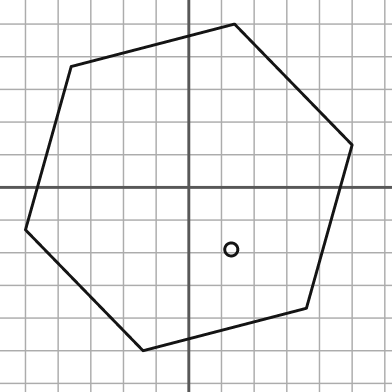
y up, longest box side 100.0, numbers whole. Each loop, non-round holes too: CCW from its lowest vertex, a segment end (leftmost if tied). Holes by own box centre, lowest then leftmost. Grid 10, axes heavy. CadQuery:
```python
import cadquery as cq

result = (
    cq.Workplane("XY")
    .moveTo(-14.0, -50.0)
    .lineTo(36.0, -37.0)
    .lineTo(50.0, 13.0)
    .lineTo(14.0, 50.0)
    .lineTo(-36.0, 37.0)
    .lineTo(-50.0, -13.0)
    .close()
    .moveTo(13.0, -19.0)
    .circle(2.0)
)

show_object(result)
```